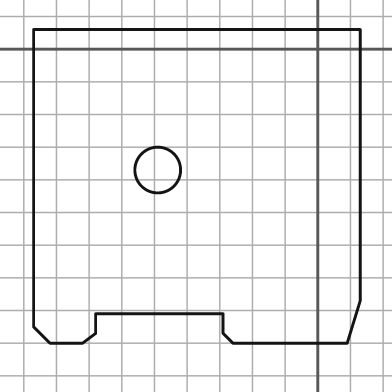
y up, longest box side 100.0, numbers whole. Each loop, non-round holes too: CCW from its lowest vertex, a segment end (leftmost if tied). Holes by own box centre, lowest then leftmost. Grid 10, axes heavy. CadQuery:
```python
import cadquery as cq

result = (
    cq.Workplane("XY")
    .moveTo(-82.0, -90.0)
    .lineTo(-72.0, -90.0)
    .lineTo(-68.0, -87.0)
    .lineTo(-68.0, -81.0)
    .lineTo(-29.0, -81.0)
    .lineTo(-29.0, -87.0)
    .lineTo(-26.0, -90.0)
    .lineTo(9.0, -90.0)
    .lineTo(13.0, -77.0)
    .lineTo(13.0, 6.0)
    .lineTo(-87.0, 6.0)
    .lineTo(-87.0, -85.0)
    .close()
    .moveTo(-49.0, -37.0)
    .circle(7.0)
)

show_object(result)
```